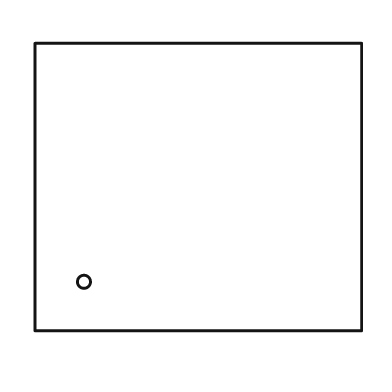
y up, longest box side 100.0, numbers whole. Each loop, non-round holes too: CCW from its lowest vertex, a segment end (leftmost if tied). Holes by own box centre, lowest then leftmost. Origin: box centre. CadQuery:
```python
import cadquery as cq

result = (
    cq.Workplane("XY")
    .moveTo(-50.0, -44.0)
    .lineTo(50.0, -44.0)
    .lineTo(50.0, 44.0)
    .lineTo(-50.0, 44.0)
    .close()
    .moveTo(-35.0, -29.0)
    .circle(2.0)
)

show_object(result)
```